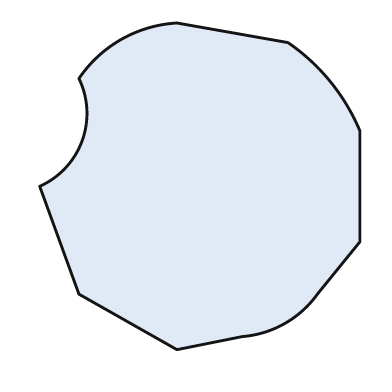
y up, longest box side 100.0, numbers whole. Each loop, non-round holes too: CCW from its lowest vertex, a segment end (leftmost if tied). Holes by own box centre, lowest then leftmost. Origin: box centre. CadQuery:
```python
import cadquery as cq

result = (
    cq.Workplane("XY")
    .moveTo(-7.0, -50.0)
    .lineTo(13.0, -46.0)
    .threePointArc((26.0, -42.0), (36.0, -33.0))
    .lineTo(49.0, -17.0)
    .lineTo(49.0, 17.0)
    .threePointArc((40.0, 32.0), (27.0, 44.0))
    .lineTo(-7.0, 50.0)
    .threePointArc((-24.0, 45.0), (-37.0, 33.0))
    .threePointArc((-36.0, 14.0), (-49.0, 0.0))
    .lineTo(-37.0, -33.0)
    .close()
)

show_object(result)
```